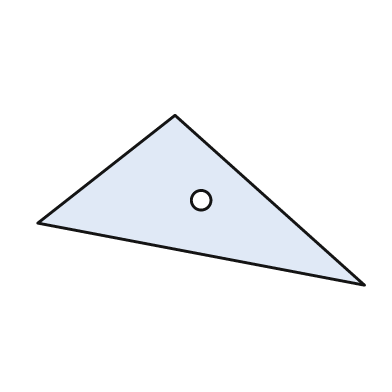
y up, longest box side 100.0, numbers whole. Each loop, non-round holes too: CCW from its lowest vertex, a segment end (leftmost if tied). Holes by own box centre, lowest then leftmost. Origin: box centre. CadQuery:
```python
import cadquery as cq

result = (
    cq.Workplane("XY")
    .moveTo(50.0, -26.0)
    .lineTo(-8.0, 26.0)
    .lineTo(-50.0, -7.0)
    .close()
    .moveTo(0.0, 0.0)
    .circle(3.0)
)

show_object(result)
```